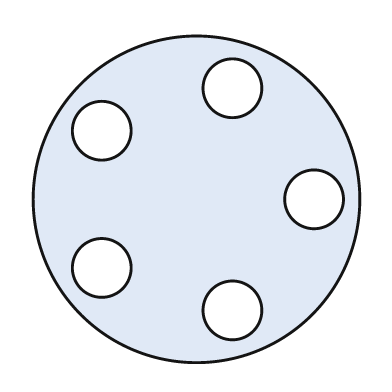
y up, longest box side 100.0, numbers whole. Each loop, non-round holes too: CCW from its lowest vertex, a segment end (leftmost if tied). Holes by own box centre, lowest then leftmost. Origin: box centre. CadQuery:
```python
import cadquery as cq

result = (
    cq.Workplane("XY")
    .moveTo(0.0, 0.0)
    .circle(50.0)
    .moveTo(11.0, -34.0)
    .circle(9.0)
    .moveTo(-29.0, -21.0)
    .circle(9.0)
    .moveTo(36.0, 0.0)
    .circle(9.0)
    .moveTo(-29.0, 21.0)
    .circle(9.0)
    .moveTo(11.0, 34.0)
    .circle(9.0)
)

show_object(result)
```